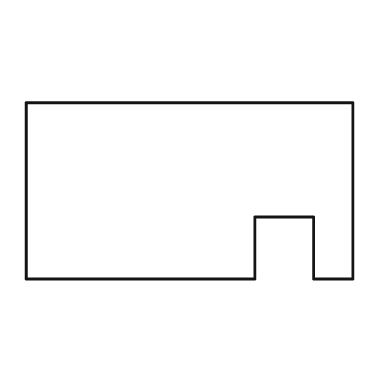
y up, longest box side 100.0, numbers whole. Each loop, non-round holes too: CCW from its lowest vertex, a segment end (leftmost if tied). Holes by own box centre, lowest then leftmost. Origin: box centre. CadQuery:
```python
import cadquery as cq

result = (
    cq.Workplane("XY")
    .moveTo(-50.0, -27.0)
    .lineTo(20.0, -27.0)
    .lineTo(20.0, -8.0)
    .lineTo(38.0, -8.0)
    .lineTo(38.0, -27.0)
    .lineTo(50.0, -27.0)
    .lineTo(50.0, 27.0)
    .lineTo(-50.0, 27.0)
    .close()
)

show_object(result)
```